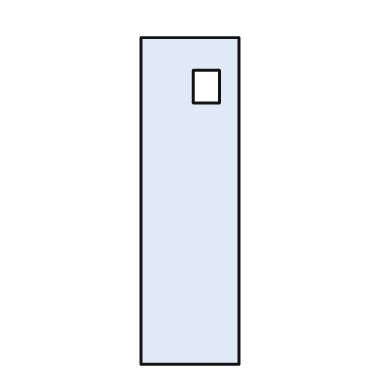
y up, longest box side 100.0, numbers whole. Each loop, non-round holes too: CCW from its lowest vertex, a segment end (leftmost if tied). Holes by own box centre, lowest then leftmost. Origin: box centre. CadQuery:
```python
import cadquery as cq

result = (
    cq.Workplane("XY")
    .moveTo(-15.0, -50.0)
    .lineTo(15.0, -50.0)
    .lineTo(15.0, 50.0)
    .lineTo(-15.0, 50.0)
    .close()
    .moveTo(1.0, 30.0)
    .lineTo(9.0, 30.0)
    .lineTo(9.0, 40.0)
    .lineTo(1.0, 40.0)
    .close()
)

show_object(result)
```